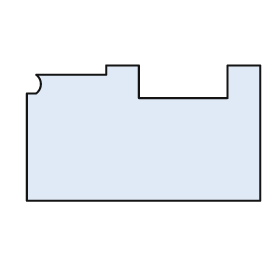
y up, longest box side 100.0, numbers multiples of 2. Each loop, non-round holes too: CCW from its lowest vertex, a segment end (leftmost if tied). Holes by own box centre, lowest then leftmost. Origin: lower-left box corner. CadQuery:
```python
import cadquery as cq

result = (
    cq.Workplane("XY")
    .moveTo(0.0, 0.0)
    .lineTo(100.0, 0.0)
    .lineTo(100.0, 58.0)
    .lineTo(86.0, 58.0)
    .lineTo(86.0, 44.0)
    .lineTo(48.0, 44.0)
    .lineTo(48.0, 58.0)
    .lineTo(34.0, 58.0)
    .lineTo(34.0, 54.0)
    .lineTo(4.0, 54.0)
    .threePointArc((6.0, 50.0), (4.0, 46.0))
    .lineTo(0.0, 46.0)
    .close()
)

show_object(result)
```